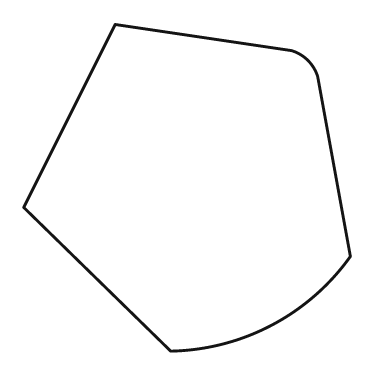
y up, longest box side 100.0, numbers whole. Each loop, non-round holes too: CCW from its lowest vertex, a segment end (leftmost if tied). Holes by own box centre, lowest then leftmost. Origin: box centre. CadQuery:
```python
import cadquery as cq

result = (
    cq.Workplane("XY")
    .moveTo(-5.0, -50.0)
    .threePointArc((26.0, -42.0), (50.0, -21.0))
    .lineTo(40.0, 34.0)
    .threePointArc((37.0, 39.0), (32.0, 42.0))
    .lineTo(-22.0, 50.0)
    .lineTo(-50.0, -6.0)
    .close()
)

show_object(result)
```